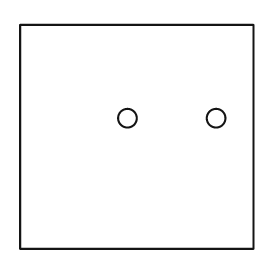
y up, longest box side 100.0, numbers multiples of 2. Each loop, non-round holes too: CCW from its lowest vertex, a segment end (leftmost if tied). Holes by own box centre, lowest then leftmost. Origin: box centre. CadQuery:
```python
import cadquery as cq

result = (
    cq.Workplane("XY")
    .moveTo(-50.0, -48.0)
    .lineTo(50.0, -48.0)
    .lineTo(50.0, 48.0)
    .lineTo(-50.0, 48.0)
    .close()
    .moveTo(-4.0, 8.0)
    .circle(4.0)
    .moveTo(34.0, 8.0)
    .circle(4.0)
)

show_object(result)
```